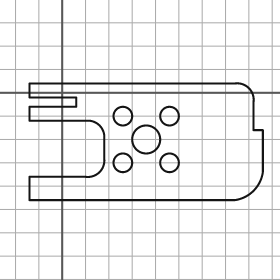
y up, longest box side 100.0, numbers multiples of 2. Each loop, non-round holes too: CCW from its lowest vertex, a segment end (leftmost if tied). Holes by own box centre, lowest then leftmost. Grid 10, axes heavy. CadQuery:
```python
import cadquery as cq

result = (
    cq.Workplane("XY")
    .moveTo(-14.0, -46.0)
    .lineTo(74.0, -46.0)
    .threePointArc((82.0, -42.0), (86.0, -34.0))
    .lineTo(86.0, -16.0)
    .lineTo(82.0, -16.0)
    .lineTo(82.0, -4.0)
    .threePointArc((80.0, 2.0), (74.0, 4.0))
    .lineTo(-14.0, 4.0)
    .lineTo(-14.0, -2.0)
    .lineTo(6.0, -2.0)
    .lineTo(6.0, -6.0)
    .lineTo(-14.0, -6.0)
    .lineTo(-14.0, -12.0)
    .lineTo(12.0, -12.0)
    .threePointArc((16.0, -14.0), (18.0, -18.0))
    .lineTo(18.0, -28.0)
    .threePointArc((16.0, -34.0), (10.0, -36.0))
    .lineTo(-14.0, -36.0)
    .close()
    .moveTo(26.0, -30.0)
    .circle(4.0)
    .moveTo(46.0, -30.0)
    .circle(4.0)
    .moveTo(36.0, -20.0)
    .circle(6.0)
    .moveTo(26.0, -10.0)
    .circle(4.0)
    .moveTo(46.0, -10.0)
    .circle(4.0)
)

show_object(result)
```